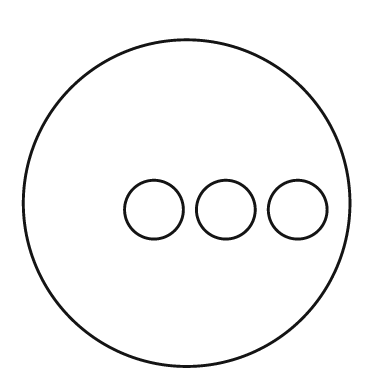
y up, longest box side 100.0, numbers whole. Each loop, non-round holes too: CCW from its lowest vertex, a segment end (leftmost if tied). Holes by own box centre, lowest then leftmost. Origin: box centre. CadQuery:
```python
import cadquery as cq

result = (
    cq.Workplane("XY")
    .moveTo(0.0, 0.0)
    .circle(50.0)
    .moveTo(-10.0, -2.0)
    .circle(9.0)
    .moveTo(12.0, -2.0)
    .circle(9.0)
    .moveTo(34.0, -2.0)
    .circle(9.0)
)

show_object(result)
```